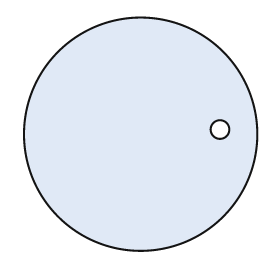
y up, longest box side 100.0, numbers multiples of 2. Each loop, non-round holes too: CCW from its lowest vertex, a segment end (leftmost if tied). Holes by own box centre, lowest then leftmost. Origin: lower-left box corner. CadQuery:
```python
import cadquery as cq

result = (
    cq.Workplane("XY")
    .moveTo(50.0, 50.0)
    .circle(50.0)
    .moveTo(84.0, 52.0)
    .circle(4.0)
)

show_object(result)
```